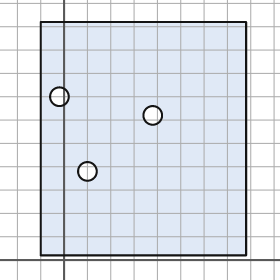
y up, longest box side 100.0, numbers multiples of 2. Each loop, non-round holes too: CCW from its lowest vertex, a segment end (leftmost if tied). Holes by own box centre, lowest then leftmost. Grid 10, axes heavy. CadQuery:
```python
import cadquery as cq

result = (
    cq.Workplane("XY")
    .moveTo(-10.0, 2.0)
    .lineTo(78.0, 2.0)
    .lineTo(78.0, 102.0)
    .lineTo(-10.0, 102.0)
    .close()
    .moveTo(10.0, 38.0)
    .circle(4.0)
    .moveTo(38.0, 62.0)
    .circle(4.0)
    .moveTo(-2.0, 70.0)
    .circle(4.0)
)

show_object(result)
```